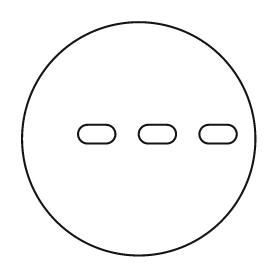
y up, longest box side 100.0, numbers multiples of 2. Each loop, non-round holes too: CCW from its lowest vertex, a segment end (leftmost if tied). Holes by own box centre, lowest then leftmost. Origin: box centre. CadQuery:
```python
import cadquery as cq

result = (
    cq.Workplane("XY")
    .moveTo(0.0, 0.0)
    .circle(50.0)
    .moveTo(-22.0, -2.0)
    .lineTo(-14.0, -2.0)
    .threePointArc((-10.0, 2.0), (-14.0, 6.0))
    .lineTo(-22.0, 6.0)
    .threePointArc((-26.0, 2.0), (-22.0, -2.0))
    .close()
    .moveTo(4.0, -2.0)
    .lineTo(12.0, -2.0)
    .threePointArc((16.0, 2.0), (12.0, 6.0))
    .lineTo(4.0, 6.0)
    .threePointArc((0.0, 2.0), (4.0, -2.0))
    .close()
    .moveTo(30.0, -2.0)
    .lineTo(38.0, -2.0)
    .threePointArc((42.0, 2.0), (38.0, 6.0))
    .lineTo(30.0, 6.0)
    .threePointArc((26.0, 2.0), (30.0, -2.0))
    .close()
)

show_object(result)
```